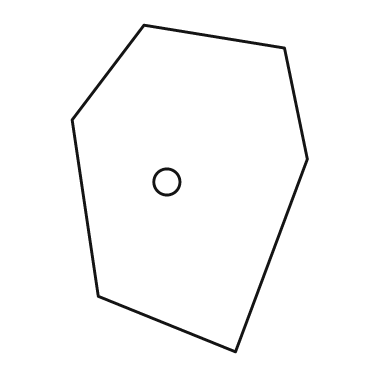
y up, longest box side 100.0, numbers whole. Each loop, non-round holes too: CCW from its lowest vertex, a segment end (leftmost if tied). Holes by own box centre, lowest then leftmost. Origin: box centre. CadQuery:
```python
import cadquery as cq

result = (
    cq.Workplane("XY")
    .moveTo(14.0, -50.0)
    .lineTo(36.0, 9.0)
    .lineTo(29.0, 43.0)
    .lineTo(-14.0, 50.0)
    .lineTo(-36.0, 21.0)
    .lineTo(-28.0, -33.0)
    .close()
    .moveTo(-7.0, 2.0)
    .circle(4.0)
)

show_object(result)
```